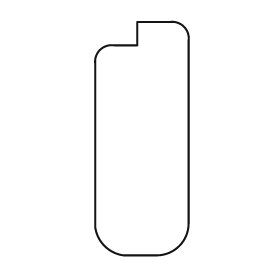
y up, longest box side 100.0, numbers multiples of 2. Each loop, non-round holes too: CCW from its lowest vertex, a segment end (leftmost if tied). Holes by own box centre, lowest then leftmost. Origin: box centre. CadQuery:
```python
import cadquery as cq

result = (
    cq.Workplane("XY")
    .moveTo(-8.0, -50.0)
    .lineTo(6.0, -50.0)
    .threePointArc((16.0, -46.0), (20.0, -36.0))
    .lineTo(20.0, 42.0)
    .threePointArc((18.0, 48.0), (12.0, 50.0))
    .lineTo(-2.0, 50.0)
    .lineTo(-2.0, 40.0)
    .lineTo(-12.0, 40.0)
    .threePointArc((-18.0, 38.0), (-20.0, 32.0))
    .lineTo(-20.0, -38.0)
    .threePointArc((-16.0, -46.0), (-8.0, -50.0))
    .close()
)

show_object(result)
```